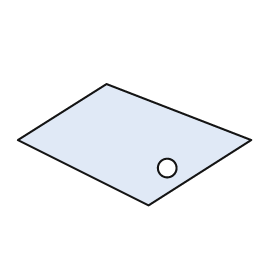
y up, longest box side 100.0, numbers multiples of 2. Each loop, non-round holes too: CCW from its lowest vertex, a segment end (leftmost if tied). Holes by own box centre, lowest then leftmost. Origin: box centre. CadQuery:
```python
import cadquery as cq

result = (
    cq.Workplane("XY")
    .moveTo(6.0, -26.0)
    .lineTo(50.0, 2.0)
    .lineTo(-12.0, 26.0)
    .lineTo(-50.0, 2.0)
    .close()
    .moveTo(14.0, -10.0)
    .circle(4.0)
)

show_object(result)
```